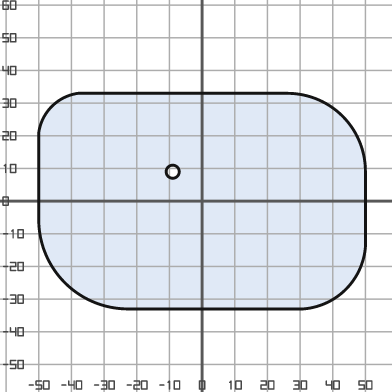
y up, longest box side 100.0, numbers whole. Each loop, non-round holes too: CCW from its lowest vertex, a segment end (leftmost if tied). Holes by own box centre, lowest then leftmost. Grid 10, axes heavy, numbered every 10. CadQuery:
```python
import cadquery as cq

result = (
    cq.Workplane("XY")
    .moveTo(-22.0, -33.0)
    .lineTo(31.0, -33.0)
    .threePointArc((44.0, -27.0), (50.0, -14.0))
    .lineTo(50.0, 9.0)
    .threePointArc((43.0, 26.0), (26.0, 33.0))
    .lineTo(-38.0, 33.0)
    .threePointArc((-46.0, 29.0), (-50.0, 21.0))
    .lineTo(-50.0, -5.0)
    .threePointArc((-42.0, -25.0), (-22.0, -33.0))
    .close()
    .moveTo(-9.0, 9.0)
    .circle(2.0)
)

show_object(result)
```